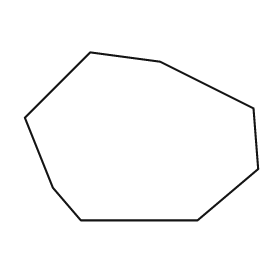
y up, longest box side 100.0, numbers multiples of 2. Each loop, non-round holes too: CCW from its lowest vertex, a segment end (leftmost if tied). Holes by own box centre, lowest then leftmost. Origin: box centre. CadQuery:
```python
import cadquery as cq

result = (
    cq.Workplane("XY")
    .moveTo(-26.0, -36.0)
    .lineTo(24.0, -36.0)
    .lineTo(50.0, -14.0)
    .lineTo(48.0, 12.0)
    .lineTo(8.0, 32.0)
    .lineTo(-22.0, 36.0)
    .lineTo(-50.0, 8.0)
    .lineTo(-38.0, -22.0)
    .close()
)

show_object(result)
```